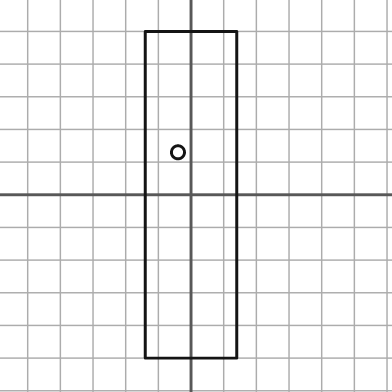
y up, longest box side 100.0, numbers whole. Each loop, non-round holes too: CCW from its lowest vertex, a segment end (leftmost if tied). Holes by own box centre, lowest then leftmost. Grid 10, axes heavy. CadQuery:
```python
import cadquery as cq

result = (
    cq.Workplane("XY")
    .moveTo(-14.0, -50.0)
    .lineTo(14.0, -50.0)
    .lineTo(14.0, 50.0)
    .lineTo(-14.0, 50.0)
    .close()
    .moveTo(-4.0, 13.0)
    .circle(2.0)
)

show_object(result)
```